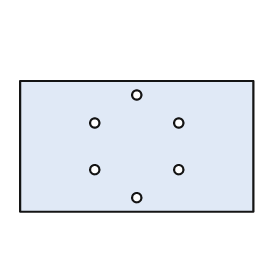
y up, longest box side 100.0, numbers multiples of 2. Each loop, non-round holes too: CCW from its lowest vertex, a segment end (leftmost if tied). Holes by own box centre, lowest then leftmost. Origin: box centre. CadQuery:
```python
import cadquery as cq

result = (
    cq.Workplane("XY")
    .moveTo(-50.0, -28.0)
    .lineTo(50.0, -28.0)
    .lineTo(50.0, 28.0)
    .lineTo(-50.0, 28.0)
    .close()
    .moveTo(0.0, -22.0)
    .circle(2.0)
    .moveTo(-18.0, -10.0)
    .circle(2.0)
    .moveTo(18.0, -10.0)
    .circle(2.0)
    .moveTo(-18.0, 10.0)
    .circle(2.0)
    .moveTo(18.0, 10.0)
    .circle(2.0)
    .moveTo(0.0, 22.0)
    .circle(2.0)
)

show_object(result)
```